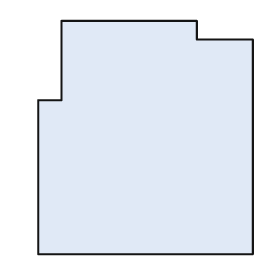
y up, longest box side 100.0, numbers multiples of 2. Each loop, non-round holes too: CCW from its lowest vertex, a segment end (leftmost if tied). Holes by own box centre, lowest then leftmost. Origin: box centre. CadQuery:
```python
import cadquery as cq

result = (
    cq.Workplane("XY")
    .moveTo(-46.0, -50.0)
    .lineTo(46.0, -50.0)
    .lineTo(46.0, 42.0)
    .lineTo(22.0, 42.0)
    .lineTo(22.0, 50.0)
    .lineTo(-36.0, 50.0)
    .lineTo(-36.0, 16.0)
    .lineTo(-46.0, 16.0)
    .close()
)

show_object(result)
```